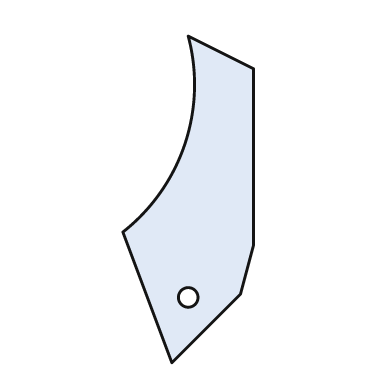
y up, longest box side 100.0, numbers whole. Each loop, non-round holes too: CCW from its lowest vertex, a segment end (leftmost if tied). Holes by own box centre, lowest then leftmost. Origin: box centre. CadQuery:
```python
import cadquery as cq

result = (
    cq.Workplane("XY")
    .moveTo(-5.0, -50.0)
    .lineTo(16.0, -29.0)
    .lineTo(20.0, -14.0)
    .lineTo(20.0, 40.0)
    .lineTo(0.0, 50.0)
    .threePointArc((-1.0, 17.0), (-20.0, -10.0))
    .close()
    .moveTo(0.0, -30.0)
    .circle(3.0)
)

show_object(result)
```